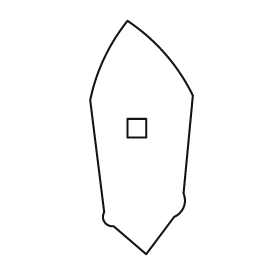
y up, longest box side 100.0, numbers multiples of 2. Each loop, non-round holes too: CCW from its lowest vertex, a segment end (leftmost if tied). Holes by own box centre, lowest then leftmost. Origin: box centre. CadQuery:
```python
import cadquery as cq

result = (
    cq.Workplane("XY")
    .moveTo(2.0, -50.0)
    .lineTo(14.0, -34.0)
    .threePointArc((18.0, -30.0), (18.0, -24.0))
    .lineTo(22.0, 18.0)
    .threePointArc((10.0, 36.0), (-6.0, 50.0))
    .threePointArc((-16.0, 34.0), (-22.0, 16.0))
    .lineTo(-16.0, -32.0)
    .threePointArc((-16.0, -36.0), (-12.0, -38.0))
    .close()
    .moveTo(-6.0, 0.0)
    .lineTo(2.0, 0.0)
    .lineTo(2.0, 8.0)
    .lineTo(-6.0, 8.0)
    .close()
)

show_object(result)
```